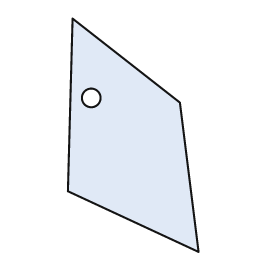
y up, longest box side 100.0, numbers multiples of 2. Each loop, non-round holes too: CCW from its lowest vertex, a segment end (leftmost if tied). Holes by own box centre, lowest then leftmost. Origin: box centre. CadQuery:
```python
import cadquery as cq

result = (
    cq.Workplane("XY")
    .moveTo(28.0, -50.0)
    .lineTo(20.0, 14.0)
    .lineTo(-26.0, 50.0)
    .lineTo(-28.0, -24.0)
    .close()
    .moveTo(-18.0, 16.0)
    .circle(4.0)
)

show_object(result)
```